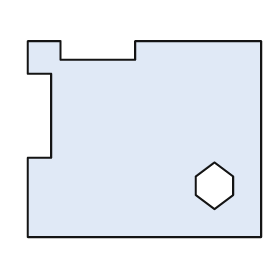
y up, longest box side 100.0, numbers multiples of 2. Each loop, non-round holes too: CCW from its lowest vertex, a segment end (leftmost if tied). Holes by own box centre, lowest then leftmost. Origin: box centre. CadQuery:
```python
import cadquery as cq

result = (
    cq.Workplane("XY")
    .moveTo(-50.0, -42.0)
    .lineTo(50.0, -42.0)
    .lineTo(50.0, 42.0)
    .lineTo(-4.0, 42.0)
    .lineTo(-4.0, 34.0)
    .lineTo(-36.0, 34.0)
    .lineTo(-36.0, 42.0)
    .lineTo(-50.0, 42.0)
    .lineTo(-50.0, 28.0)
    .lineTo(-40.0, 28.0)
    .lineTo(-40.0, -8.0)
    .lineTo(-50.0, -8.0)
    .close()
    .moveTo(30.0, -30.0)
    .lineTo(38.0, -24.0)
    .lineTo(38.0, -16.0)
    .lineTo(30.0, -10.0)
    .lineTo(22.0, -16.0)
    .lineTo(22.0, -24.0)
    .close()
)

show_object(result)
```